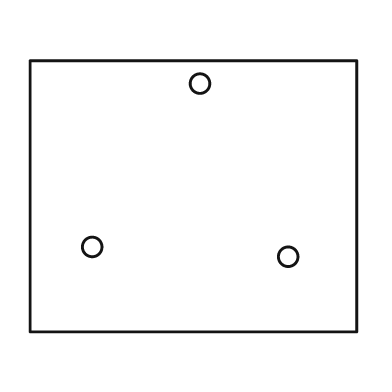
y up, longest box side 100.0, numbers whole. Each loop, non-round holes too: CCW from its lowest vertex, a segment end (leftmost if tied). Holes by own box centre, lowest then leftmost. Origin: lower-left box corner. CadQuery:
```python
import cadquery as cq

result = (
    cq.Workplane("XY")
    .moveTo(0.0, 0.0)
    .lineTo(100.0, 0.0)
    .lineTo(100.0, 83.0)
    .lineTo(0.0, 83.0)
    .close()
    .moveTo(79.0, 23.0)
    .circle(3.0)
    .moveTo(19.0, 26.0)
    .circle(3.0)
    .moveTo(52.0, 76.0)
    .circle(3.0)
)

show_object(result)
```